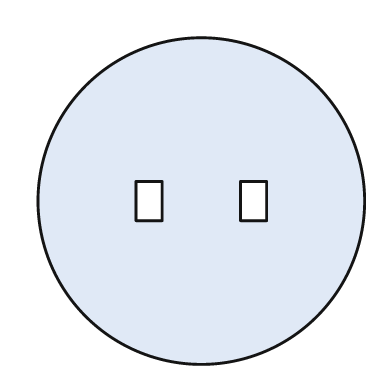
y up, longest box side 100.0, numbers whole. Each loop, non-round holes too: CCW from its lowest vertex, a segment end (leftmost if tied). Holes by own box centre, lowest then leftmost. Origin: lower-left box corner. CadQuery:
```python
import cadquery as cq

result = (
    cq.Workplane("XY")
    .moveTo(50.0, 50.0)
    .circle(50.0)
    .moveTo(30.0, 44.0)
    .lineTo(38.0, 44.0)
    .lineTo(38.0, 56.0)
    .lineTo(30.0, 56.0)
    .close()
    .moveTo(62.0, 44.0)
    .lineTo(70.0, 44.0)
    .lineTo(70.0, 56.0)
    .lineTo(62.0, 56.0)
    .close()
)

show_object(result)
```